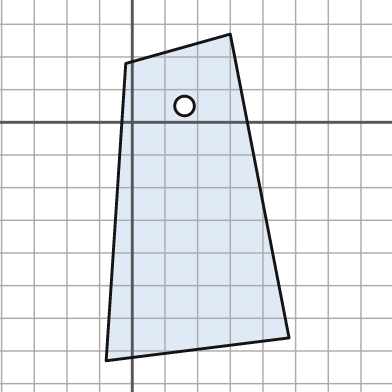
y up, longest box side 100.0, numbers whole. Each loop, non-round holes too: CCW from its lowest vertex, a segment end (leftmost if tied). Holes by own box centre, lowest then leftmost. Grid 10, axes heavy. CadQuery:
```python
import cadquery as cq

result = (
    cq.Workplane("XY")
    .moveTo(-8.0, -73.0)
    .lineTo(48.0, -66.0)
    .lineTo(30.0, 27.0)
    .lineTo(-2.0, 18.0)
    .close()
    .moveTo(16.0, 5.0)
    .circle(3.0)
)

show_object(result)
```